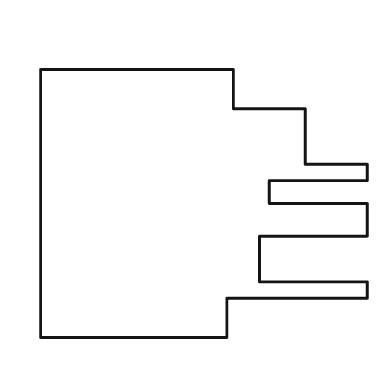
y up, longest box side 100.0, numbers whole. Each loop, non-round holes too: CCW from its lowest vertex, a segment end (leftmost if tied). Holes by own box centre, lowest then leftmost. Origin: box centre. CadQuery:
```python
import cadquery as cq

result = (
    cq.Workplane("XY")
    .moveTo(-50.0, -41.0)
    .lineTo(7.0, -41.0)
    .lineTo(7.0, -29.0)
    .lineTo(50.0, -29.0)
    .lineTo(50.0, -24.0)
    .lineTo(17.0, -24.0)
    .lineTo(17.0, -10.0)
    .lineTo(50.0, -10.0)
    .lineTo(50.0, 0.0)
    .lineTo(20.0, 0.0)
    .lineTo(20.0, 7.0)
    .lineTo(50.0, 7.0)
    .lineTo(50.0, 12.0)
    .lineTo(31.0, 12.0)
    .lineTo(31.0, 29.0)
    .lineTo(9.0, 29.0)
    .lineTo(9.0, 41.0)
    .lineTo(-50.0, 41.0)
    .close()
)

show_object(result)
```